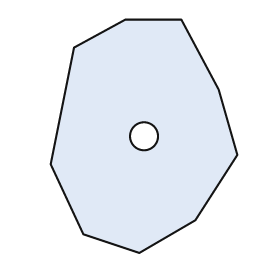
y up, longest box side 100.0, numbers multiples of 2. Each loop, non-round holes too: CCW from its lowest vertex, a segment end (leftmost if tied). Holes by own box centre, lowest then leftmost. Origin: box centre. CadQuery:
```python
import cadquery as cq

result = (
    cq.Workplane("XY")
    .moveTo(-2.0, -50.0)
    .lineTo(22.0, -36.0)
    .lineTo(40.0, -8.0)
    .lineTo(32.0, 20.0)
    .lineTo(16.0, 50.0)
    .lineTo(-8.0, 50.0)
    .lineTo(-30.0, 38.0)
    .lineTo(-40.0, -12.0)
    .lineTo(-26.0, -42.0)
    .close()
    .moveTo(0.0, 0.0)
    .circle(6.0)
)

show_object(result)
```